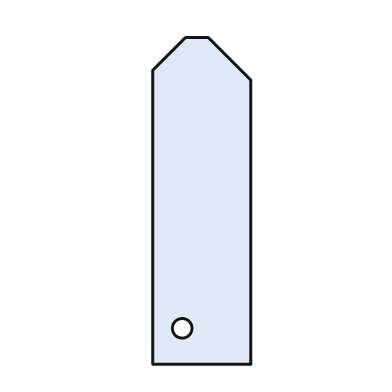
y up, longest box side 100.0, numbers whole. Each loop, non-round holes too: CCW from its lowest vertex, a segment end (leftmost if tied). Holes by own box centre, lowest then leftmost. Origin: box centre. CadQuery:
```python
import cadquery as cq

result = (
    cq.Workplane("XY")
    .moveTo(-15.0, -50.0)
    .lineTo(15.0, -50.0)
    .lineTo(15.0, 37.0)
    .lineTo(2.0, 50.0)
    .lineTo(-5.0, 50.0)
    .lineTo(-15.0, 40.0)
    .close()
    .moveTo(-6.0, -39.0)
    .circle(3.0)
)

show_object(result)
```